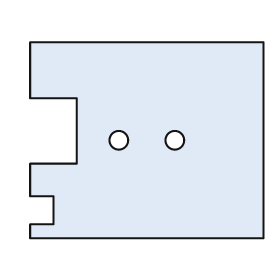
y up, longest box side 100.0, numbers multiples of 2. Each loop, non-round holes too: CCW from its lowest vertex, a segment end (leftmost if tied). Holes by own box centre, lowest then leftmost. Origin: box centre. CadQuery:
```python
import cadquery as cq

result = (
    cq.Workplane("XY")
    .moveTo(-50.0, -42.0)
    .lineTo(50.0, -42.0)
    .lineTo(50.0, 42.0)
    .lineTo(-50.0, 42.0)
    .lineTo(-50.0, 18.0)
    .lineTo(-30.0, 18.0)
    .lineTo(-30.0, -10.0)
    .lineTo(-50.0, -10.0)
    .lineTo(-50.0, -24.0)
    .lineTo(-40.0, -24.0)
    .lineTo(-40.0, -36.0)
    .lineTo(-50.0, -36.0)
    .close()
    .moveTo(-12.0, 0.0)
    .circle(4.0)
    .moveTo(12.0, 0.0)
    .circle(4.0)
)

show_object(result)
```